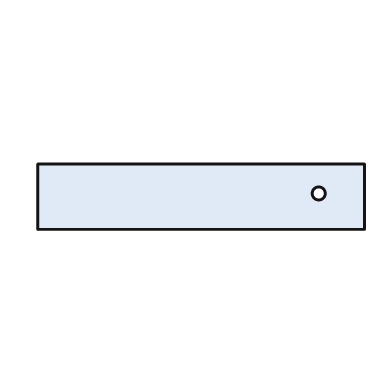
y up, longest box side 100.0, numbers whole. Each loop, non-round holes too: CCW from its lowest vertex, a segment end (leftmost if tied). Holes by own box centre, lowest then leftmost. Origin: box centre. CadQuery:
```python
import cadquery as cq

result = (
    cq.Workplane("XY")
    .moveTo(-50.0, -10.0)
    .lineTo(50.0, -10.0)
    .lineTo(50.0, 10.0)
    .lineTo(-50.0, 10.0)
    .close()
    .moveTo(36.0, 1.0)
    .circle(2.0)
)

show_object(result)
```